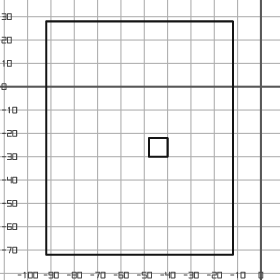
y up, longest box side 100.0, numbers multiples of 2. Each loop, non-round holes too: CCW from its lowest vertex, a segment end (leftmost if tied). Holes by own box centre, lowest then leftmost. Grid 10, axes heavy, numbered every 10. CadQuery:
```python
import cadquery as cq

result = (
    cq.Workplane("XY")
    .moveTo(-92.0, -72.0)
    .lineTo(-12.0, -72.0)
    .lineTo(-12.0, 28.0)
    .lineTo(-92.0, 28.0)
    .close()
    .moveTo(-48.0, -30.0)
    .lineTo(-40.0, -30.0)
    .lineTo(-40.0, -22.0)
    .lineTo(-48.0, -22.0)
    .close()
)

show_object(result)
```